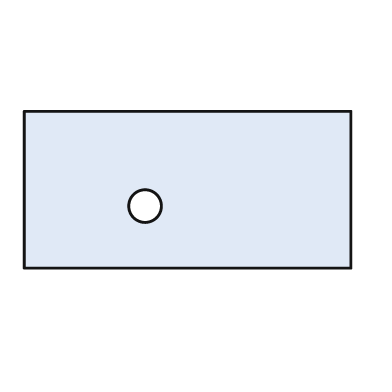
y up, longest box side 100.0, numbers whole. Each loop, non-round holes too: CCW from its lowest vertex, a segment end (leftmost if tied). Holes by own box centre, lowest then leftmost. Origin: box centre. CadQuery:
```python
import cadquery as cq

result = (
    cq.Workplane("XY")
    .moveTo(-50.0, -24.0)
    .lineTo(50.0, -24.0)
    .lineTo(50.0, 24.0)
    .lineTo(-50.0, 24.0)
    .close()
    .moveTo(-13.0, -5.0)
    .circle(5.0)
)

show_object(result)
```